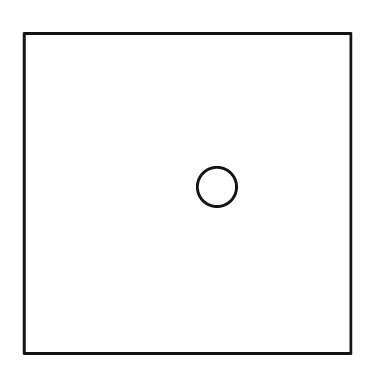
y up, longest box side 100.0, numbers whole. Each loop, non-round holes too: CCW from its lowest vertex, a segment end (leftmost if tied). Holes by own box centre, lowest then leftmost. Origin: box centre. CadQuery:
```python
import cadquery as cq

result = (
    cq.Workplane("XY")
    .moveTo(-50.0, -49.0)
    .lineTo(50.0, -49.0)
    .lineTo(50.0, 49.0)
    .lineTo(-50.0, 49.0)
    .close()
    .moveTo(9.0, 2.0)
    .circle(6.0)
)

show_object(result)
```